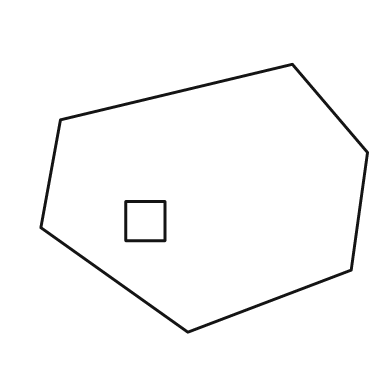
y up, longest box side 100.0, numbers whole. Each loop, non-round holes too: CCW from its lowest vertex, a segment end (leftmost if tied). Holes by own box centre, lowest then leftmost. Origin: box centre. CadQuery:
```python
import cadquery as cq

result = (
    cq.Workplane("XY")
    .moveTo(-5.0, -41.0)
    .lineTo(45.0, -22.0)
    .lineTo(50.0, 14.0)
    .lineTo(27.0, 41.0)
    .lineTo(-44.0, 24.0)
    .lineTo(-50.0, -9.0)
    .close()
    .moveTo(-24.0, -13.0)
    .lineTo(-12.0, -13.0)
    .lineTo(-12.0, -1.0)
    .lineTo(-24.0, -1.0)
    .close()
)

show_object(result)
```